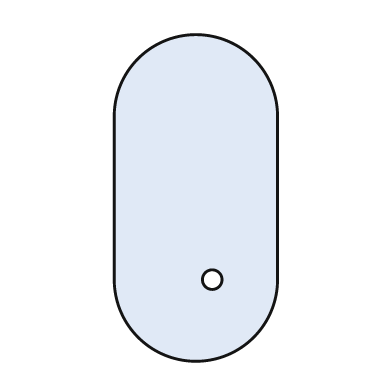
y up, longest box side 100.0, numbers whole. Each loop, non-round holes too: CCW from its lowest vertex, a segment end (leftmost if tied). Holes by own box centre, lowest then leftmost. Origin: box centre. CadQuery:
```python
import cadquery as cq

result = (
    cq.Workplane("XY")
    .moveTo(-25.0, -25.0)
    .threePointArc((0.0, -50.0), (25.0, -25.0))
    .lineTo(25.0, 25.0)
    .threePointArc((0.0, 50.0), (-25.0, 25.0))
    .close()
    .moveTo(5.0, -25.0)
    .circle(3.0)
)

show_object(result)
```